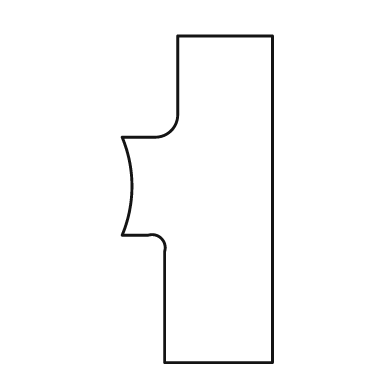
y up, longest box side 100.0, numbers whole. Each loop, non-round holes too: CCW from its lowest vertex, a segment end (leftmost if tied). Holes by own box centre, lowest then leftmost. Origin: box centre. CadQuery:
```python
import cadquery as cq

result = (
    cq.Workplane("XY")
    .moveTo(-10.0, -50.0)
    .lineTo(23.0, -50.0)
    .lineTo(23.0, 50.0)
    .lineTo(-6.0, 50.0)
    .lineTo(-6.0, 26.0)
    .threePointArc((-8.0, 21.0), (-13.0, 19.0))
    .lineTo(-23.0, 19.0)
    .threePointArc((-20.0, 4.0), (-23.0, -11.0))
    .lineTo(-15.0, -11.0)
    .threePointArc((-11.0, -12.0), (-10.0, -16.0))
    .close()
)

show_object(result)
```